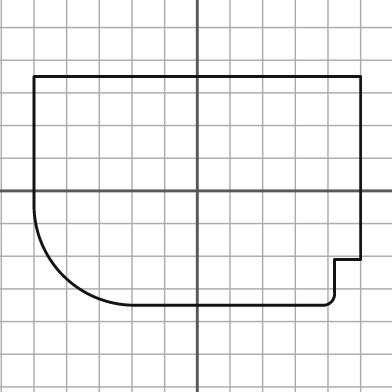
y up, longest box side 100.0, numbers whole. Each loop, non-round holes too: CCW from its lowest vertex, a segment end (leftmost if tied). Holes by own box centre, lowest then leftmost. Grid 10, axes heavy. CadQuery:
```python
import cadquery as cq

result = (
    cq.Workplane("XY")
    .moveTo(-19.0, -35.0)
    .lineTo(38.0, -35.0)
    .threePointArc((41.0, -34.0), (42.0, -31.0))
    .lineTo(42.0, -21.0)
    .lineTo(50.0, -21.0)
    .lineTo(50.0, 35.0)
    .lineTo(-50.0, 35.0)
    .lineTo(-50.0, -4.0)
    .threePointArc((-41.0, -26.0), (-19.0, -35.0))
    .close()
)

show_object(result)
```